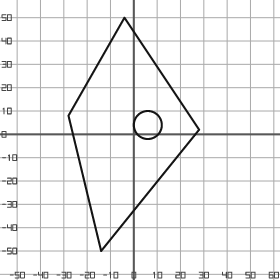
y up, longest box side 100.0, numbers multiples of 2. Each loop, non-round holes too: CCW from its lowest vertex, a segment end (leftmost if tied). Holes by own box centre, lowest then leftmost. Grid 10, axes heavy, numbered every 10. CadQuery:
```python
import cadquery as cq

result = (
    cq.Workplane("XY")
    .moveTo(-14.0, -50.0)
    .lineTo(28.0, 2.0)
    .lineTo(-4.0, 50.0)
    .lineTo(-28.0, 8.0)
    .close()
    .moveTo(6.0, 4.0)
    .circle(6.0)
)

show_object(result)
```